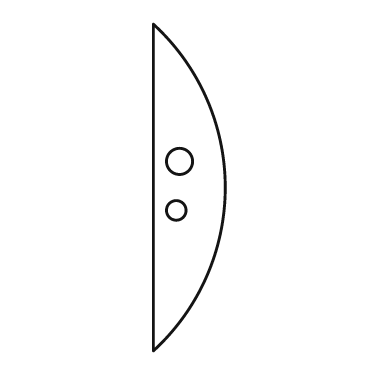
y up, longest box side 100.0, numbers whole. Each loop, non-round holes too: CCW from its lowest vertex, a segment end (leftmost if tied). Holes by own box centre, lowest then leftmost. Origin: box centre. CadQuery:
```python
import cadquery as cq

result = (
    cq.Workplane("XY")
    .moveTo(-11.0, -50.0)
    .threePointArc((11.0, 0.0), (-11.0, 50.0))
    .close()
    .moveTo(-4.0, -7.0)
    .circle(3.0)
    .moveTo(-3.0, 8.0)
    .circle(4.0)
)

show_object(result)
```